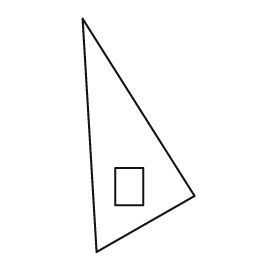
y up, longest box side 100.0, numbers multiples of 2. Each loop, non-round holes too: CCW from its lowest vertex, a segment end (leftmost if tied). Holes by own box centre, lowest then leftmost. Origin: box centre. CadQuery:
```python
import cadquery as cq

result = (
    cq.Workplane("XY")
    .moveTo(-18.0, -50.0)
    .lineTo(24.0, -26.0)
    .lineTo(-24.0, 50.0)
    .close()
    .moveTo(-10.0, -30.0)
    .lineTo(2.0, -30.0)
    .lineTo(2.0, -14.0)
    .lineTo(-10.0, -14.0)
    .close()
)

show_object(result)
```